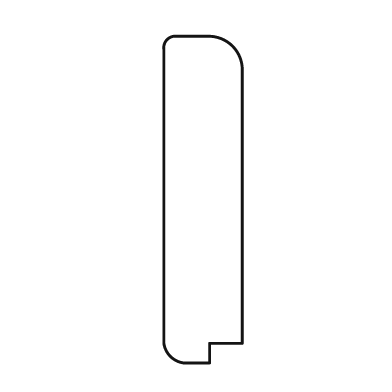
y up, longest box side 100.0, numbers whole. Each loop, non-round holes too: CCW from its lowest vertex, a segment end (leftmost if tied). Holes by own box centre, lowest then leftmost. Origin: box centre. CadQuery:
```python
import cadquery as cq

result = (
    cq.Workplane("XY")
    .moveTo(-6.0, -50.0)
    .lineTo(2.0, -50.0)
    .lineTo(2.0, -44.0)
    .lineTo(12.0, -44.0)
    .lineTo(12.0, 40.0)
    .threePointArc((9.0, 47.0), (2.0, 50.0))
    .lineTo(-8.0, 50.0)
    .threePointArc((-11.0, 49.0), (-12.0, 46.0))
    .lineTo(-12.0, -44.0)
    .threePointArc((-10.0, -48.0), (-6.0, -50.0))
    .close()
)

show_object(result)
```